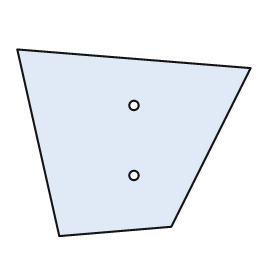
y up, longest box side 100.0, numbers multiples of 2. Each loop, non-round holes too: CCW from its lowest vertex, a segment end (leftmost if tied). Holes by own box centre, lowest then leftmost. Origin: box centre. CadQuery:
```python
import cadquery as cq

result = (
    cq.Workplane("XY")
    .moveTo(-32.0, -40.0)
    .lineTo(16.0, -36.0)
    .lineTo(50.0, 32.0)
    .lineTo(-50.0, 40.0)
    .close()
    .moveTo(0.0, -14.0)
    .circle(2.0)
    .moveTo(0.0, 16.0)
    .circle(2.0)
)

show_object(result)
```